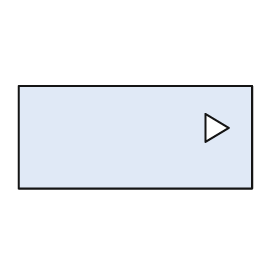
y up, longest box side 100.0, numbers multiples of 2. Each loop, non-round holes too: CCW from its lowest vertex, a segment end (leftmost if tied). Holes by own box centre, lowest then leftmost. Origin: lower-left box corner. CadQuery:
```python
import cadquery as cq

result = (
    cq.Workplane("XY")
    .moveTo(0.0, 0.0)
    .lineTo(100.0, 0.0)
    .lineTo(100.0, 44.0)
    .lineTo(0.0, 44.0)
    .close()
    .moveTo(80.0, 20.0)
    .lineTo(90.0, 26.0)
    .lineTo(80.0, 32.0)
    .close()
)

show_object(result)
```